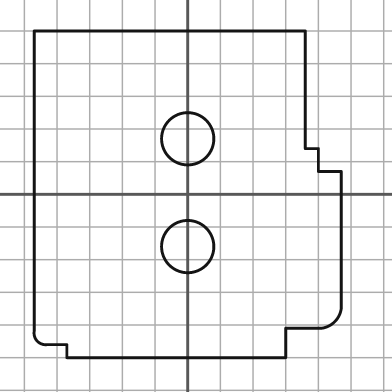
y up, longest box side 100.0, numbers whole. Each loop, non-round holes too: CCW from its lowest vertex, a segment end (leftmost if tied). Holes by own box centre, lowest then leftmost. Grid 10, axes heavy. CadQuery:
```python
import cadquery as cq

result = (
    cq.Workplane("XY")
    .moveTo(-37.0, -50.0)
    .lineTo(30.0, -50.0)
    .lineTo(30.0, -41.0)
    .lineTo(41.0, -41.0)
    .threePointArc((45.0, -39.0), (47.0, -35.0))
    .lineTo(47.0, 7.0)
    .lineTo(40.0, 7.0)
    .lineTo(40.0, 14.0)
    .lineTo(36.0, 14.0)
    .lineTo(36.0, 50.0)
    .lineTo(-47.0, 50.0)
    .lineTo(-47.0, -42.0)
    .threePointArc((-46.0, -45.0), (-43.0, -46.0))
    .lineTo(-37.0, -46.0)
    .close()
    .moveTo(0.0, -16.0)
    .circle(8.0)
    .moveTo(0.0, 17.0)
    .circle(8.0)
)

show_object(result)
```